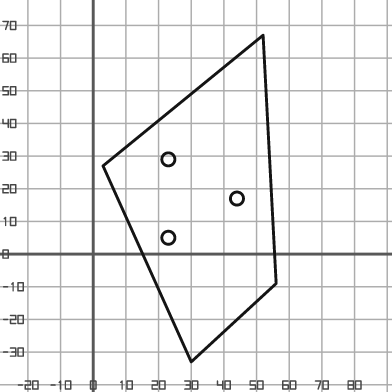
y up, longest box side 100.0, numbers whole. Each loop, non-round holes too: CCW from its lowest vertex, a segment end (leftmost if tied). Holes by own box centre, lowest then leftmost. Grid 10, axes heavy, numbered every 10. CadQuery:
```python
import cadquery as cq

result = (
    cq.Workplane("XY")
    .moveTo(30.0, -33.0)
    .lineTo(56.0, -9.0)
    .lineTo(52.0, 67.0)
    .lineTo(3.0, 27.0)
    .close()
    .moveTo(23.0, 5.0)
    .circle(2.0)
    .moveTo(44.0, 17.0)
    .circle(2.0)
    .moveTo(23.0, 29.0)
    .circle(2.0)
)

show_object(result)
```